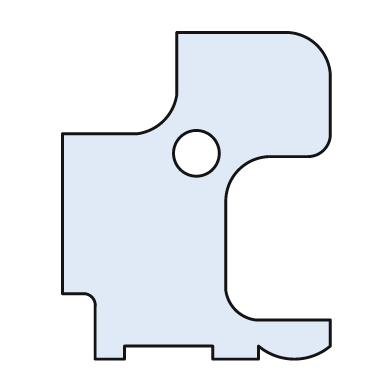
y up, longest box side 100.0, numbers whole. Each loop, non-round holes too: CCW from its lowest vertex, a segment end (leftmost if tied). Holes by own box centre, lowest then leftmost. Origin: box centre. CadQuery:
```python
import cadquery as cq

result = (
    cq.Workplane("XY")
    .moveTo(-31.0, -50.0)
    .lineTo(-22.0, -50.0)
    .lineTo(-22.0, -46.0)
    .lineTo(5.0, -46.0)
    .lineTo(5.0, -50.0)
    .lineTo(19.0, -50.0)
    .lineTo(19.0, -46.0)
    .threePointArc((30.0, -50.0), (41.0, -46.0))
    .lineTo(41.0, -38.0)
    .lineTo(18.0, -38.0)
    .threePointArc((12.0, -35.0), (9.0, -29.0))
    .lineTo(9.0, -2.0)
    .threePointArc((13.0, 8.0), (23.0, 12.0))
    .lineTo(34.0, 12.0)
    .threePointArc((39.0, 14.0), (41.0, 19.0))
    .lineTo(41.0, 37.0)
    .threePointArc((37.0, 46.0), (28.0, 50.0))
    .lineTo(-6.0, 50.0)
    .lineTo(-6.0, 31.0)
    .threePointArc((-10.0, 23.0), (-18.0, 19.0))
    .lineTo(-41.0, 19.0)
    .lineTo(-41.0, -30.0)
    .lineTo(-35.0, -30.0)
    .threePointArc((-32.0, -31.0), (-31.0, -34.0))
    .close()
    .moveTo(0.0, 13.0)
    .circle(7.0)
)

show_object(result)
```